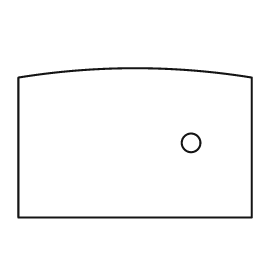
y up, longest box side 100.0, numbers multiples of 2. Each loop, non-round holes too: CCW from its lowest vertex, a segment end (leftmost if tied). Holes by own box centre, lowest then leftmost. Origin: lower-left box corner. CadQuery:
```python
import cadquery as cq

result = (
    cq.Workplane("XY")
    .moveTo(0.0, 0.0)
    .lineTo(100.0, 0.0)
    .lineTo(100.0, 60.0)
    .threePointArc((50.0, 64.0), (0.0, 60.0))
    .close()
    .moveTo(74.0, 32.0)
    .circle(4.0)
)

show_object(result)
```